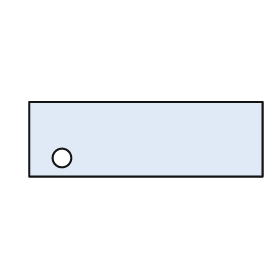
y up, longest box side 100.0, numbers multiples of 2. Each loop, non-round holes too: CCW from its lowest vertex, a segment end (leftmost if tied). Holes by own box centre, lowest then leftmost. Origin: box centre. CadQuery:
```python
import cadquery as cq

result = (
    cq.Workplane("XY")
    .moveTo(-50.0, -16.0)
    .lineTo(50.0, -16.0)
    .lineTo(50.0, 16.0)
    .lineTo(-50.0, 16.0)
    .close()
    .moveTo(-36.0, -8.0)
    .circle(4.0)
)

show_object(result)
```